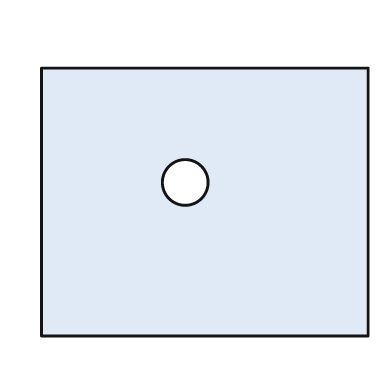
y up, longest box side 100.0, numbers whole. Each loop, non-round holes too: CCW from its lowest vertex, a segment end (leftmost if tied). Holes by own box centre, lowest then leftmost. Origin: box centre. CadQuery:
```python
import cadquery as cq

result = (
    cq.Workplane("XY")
    .moveTo(-50.0, -41.0)
    .lineTo(50.0, -41.0)
    .lineTo(50.0, 41.0)
    .lineTo(-50.0, 41.0)
    .close()
    .moveTo(-6.0, 6.0)
    .circle(7.0)
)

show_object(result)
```